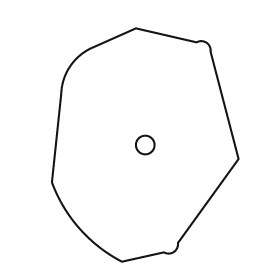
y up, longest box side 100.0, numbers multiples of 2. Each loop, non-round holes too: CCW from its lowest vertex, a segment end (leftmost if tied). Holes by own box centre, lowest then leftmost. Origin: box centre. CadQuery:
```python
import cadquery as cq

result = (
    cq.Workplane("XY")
    .moveTo(-10.0, -50.0)
    .lineTo(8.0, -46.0)
    .threePointArc((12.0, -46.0), (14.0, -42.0))
    .lineTo(40.0, -6.0)
    .lineTo(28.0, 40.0)
    .threePointArc((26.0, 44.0), (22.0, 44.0))
    .lineTo(-4.0, 50.0)
    .lineTo(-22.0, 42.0)
    .threePointArc((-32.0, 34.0), (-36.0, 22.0))
    .lineTo(-40.0, -16.0)
    .threePointArc((-28.0, -36.0), (-10.0, -50.0))
    .close()
    .moveTo(0.0, 0.0)
    .circle(4.0)
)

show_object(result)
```